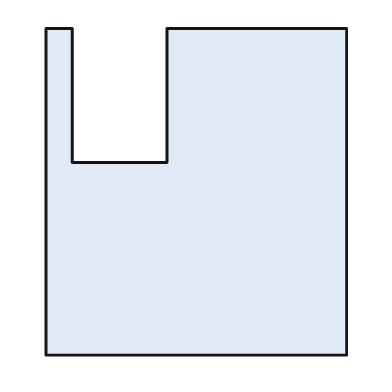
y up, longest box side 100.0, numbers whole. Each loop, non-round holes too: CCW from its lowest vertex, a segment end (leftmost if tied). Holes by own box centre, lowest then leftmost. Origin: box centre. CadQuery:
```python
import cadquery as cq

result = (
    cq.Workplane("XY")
    .moveTo(-46.0, -50.0)
    .lineTo(46.0, -50.0)
    .lineTo(46.0, 50.0)
    .lineTo(-9.0, 50.0)
    .lineTo(-9.0, 9.0)
    .lineTo(-38.0, 9.0)
    .lineTo(-38.0, 50.0)
    .lineTo(-46.0, 50.0)
    .close()
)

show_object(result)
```